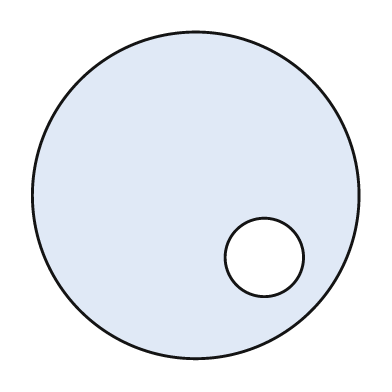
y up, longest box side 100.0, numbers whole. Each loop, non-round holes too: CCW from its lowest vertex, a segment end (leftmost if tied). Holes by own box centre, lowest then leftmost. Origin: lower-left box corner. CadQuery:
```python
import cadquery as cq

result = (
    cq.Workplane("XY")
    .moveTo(50.0, 50.0)
    .circle(50.0)
    .moveTo(71.0, 31.0)
    .circle(12.0)
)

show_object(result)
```